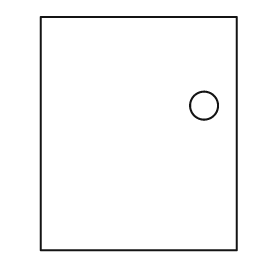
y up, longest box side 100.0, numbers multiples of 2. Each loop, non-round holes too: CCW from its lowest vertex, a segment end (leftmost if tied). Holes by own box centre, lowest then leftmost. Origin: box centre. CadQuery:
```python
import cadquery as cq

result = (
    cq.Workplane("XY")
    .moveTo(-42.0, -50.0)
    .lineTo(42.0, -50.0)
    .lineTo(42.0, 50.0)
    .lineTo(-42.0, 50.0)
    .close()
    .moveTo(28.0, 12.0)
    .circle(6.0)
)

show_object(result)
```